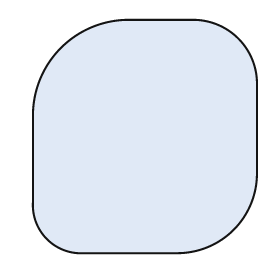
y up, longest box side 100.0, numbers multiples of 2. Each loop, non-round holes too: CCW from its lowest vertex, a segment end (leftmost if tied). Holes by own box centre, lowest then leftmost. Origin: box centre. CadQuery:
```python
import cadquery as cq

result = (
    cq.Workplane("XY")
    .moveTo(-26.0, -50.0)
    .lineTo(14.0, -50.0)
    .threePointArc((38.0, -40.0), (48.0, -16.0))
    .lineTo(48.0, 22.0)
    .threePointArc((40.0, 42.0), (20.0, 50.0))
    .lineTo(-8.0, 50.0)
    .threePointArc((-36.0, 38.0), (-48.0, 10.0))
    .lineTo(-48.0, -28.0)
    .threePointArc((-42.0, -44.0), (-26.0, -50.0))
    .close()
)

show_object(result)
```